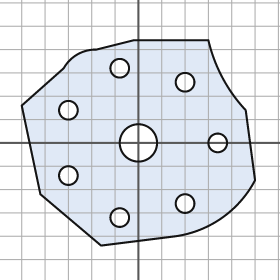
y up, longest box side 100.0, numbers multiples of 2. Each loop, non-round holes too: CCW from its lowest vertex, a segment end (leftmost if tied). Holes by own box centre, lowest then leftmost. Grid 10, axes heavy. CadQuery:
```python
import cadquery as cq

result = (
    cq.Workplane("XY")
    .moveTo(-16.0, -44.0)
    .lineTo(16.0, -40.0)
    .threePointArc((36.0, -32.0), (50.0, -16.0))
    .lineTo(46.0, 14.0)
    .threePointArc((36.0, 28.0), (30.0, 44.0))
    .lineTo(-2.0, 44.0)
    .lineTo(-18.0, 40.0)
    .threePointArc((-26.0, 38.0), (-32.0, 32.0))
    .lineTo(-50.0, 16.0)
    .lineTo(-42.0, -22.0)
    .close()
    .moveTo(-8.0, -32.0)
    .circle(4.0)
    .moveTo(20.0, -26.0)
    .circle(4.0)
    .moveTo(-30.0, -14.0)
    .circle(4.0)
    .moveTo(0.0, 0.0)
    .circle(8.0)
    .moveTo(34.0, 0.0)
    .circle(4.0)
    .moveTo(-30.0, 14.0)
    .circle(4.0)
    .moveTo(20.0, 26.0)
    .circle(4.0)
    .moveTo(-8.0, 32.0)
    .circle(4.0)
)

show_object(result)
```